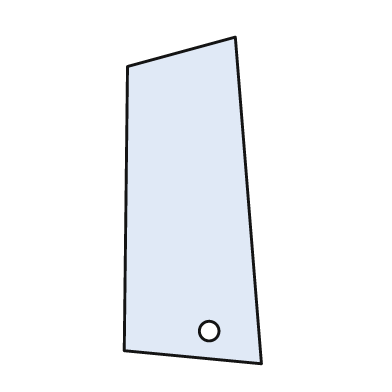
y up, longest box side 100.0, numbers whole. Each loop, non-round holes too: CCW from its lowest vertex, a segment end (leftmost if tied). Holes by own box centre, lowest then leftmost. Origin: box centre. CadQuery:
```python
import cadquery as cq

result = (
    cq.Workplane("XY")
    .moveTo(21.0, -50.0)
    .lineTo(13.0, 50.0)
    .lineTo(-20.0, 41.0)
    .lineTo(-21.0, -46.0)
    .close()
    .moveTo(5.0, -40.0)
    .circle(3.0)
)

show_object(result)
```